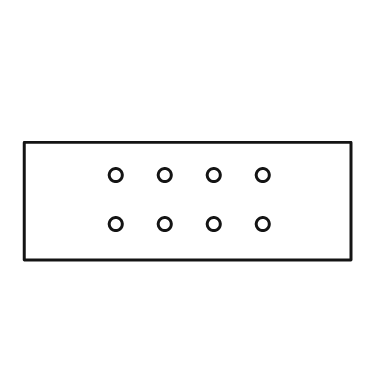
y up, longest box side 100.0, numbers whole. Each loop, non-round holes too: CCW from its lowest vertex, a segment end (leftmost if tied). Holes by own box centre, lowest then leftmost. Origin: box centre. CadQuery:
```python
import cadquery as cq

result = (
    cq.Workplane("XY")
    .moveTo(-50.0, -18.0)
    .lineTo(50.0, -18.0)
    .lineTo(50.0, 18.0)
    .lineTo(-50.0, 18.0)
    .close()
    .moveTo(-22.0, -7.0)
    .circle(2.0)
    .moveTo(-7.0, -7.0)
    .circle(2.0)
    .moveTo(8.0, -7.0)
    .circle(2.0)
    .moveTo(23.0, -7.0)
    .circle(2.0)
    .moveTo(-22.0, 8.0)
    .circle(2.0)
    .moveTo(-7.0, 8.0)
    .circle(2.0)
    .moveTo(8.0, 8.0)
    .circle(2.0)
    .moveTo(23.0, 8.0)
    .circle(2.0)
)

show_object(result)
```